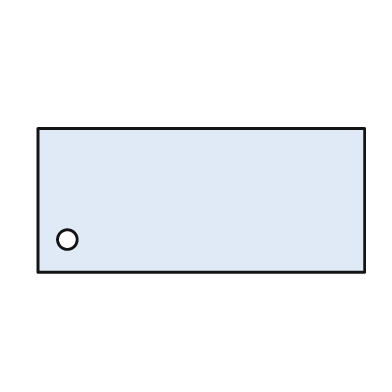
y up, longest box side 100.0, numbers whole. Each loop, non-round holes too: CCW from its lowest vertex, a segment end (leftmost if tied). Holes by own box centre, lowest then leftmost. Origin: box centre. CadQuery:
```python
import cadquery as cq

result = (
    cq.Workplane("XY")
    .moveTo(-50.0, -22.0)
    .lineTo(50.0, -22.0)
    .lineTo(50.0, 22.0)
    .lineTo(-50.0, 22.0)
    .close()
    .moveTo(-41.0, -12.0)
    .circle(3.0)
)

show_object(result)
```